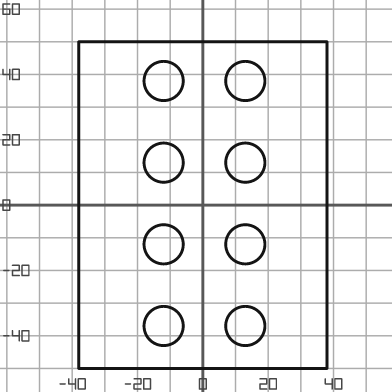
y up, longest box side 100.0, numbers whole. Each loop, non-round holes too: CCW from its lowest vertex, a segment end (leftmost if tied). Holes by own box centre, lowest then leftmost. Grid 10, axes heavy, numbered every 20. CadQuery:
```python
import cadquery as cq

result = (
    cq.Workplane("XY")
    .moveTo(-38.0, -50.0)
    .lineTo(38.0, -50.0)
    .lineTo(38.0, 50.0)
    .lineTo(-38.0, 50.0)
    .close()
    .moveTo(-12.0, -37.0)
    .circle(6.0)
    .moveTo(13.0, -37.0)
    .circle(6.0)
    .moveTo(-12.0, -12.0)
    .circle(6.0)
    .moveTo(13.0, -12.0)
    .circle(6.0)
    .moveTo(-12.0, 13.0)
    .circle(6.0)
    .moveTo(13.0, 13.0)
    .circle(6.0)
    .moveTo(-12.0, 38.0)
    .circle(6.0)
    .moveTo(13.0, 38.0)
    .circle(6.0)
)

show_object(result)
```